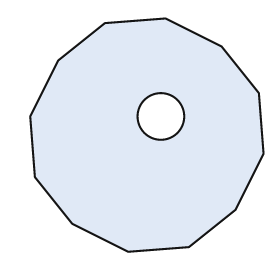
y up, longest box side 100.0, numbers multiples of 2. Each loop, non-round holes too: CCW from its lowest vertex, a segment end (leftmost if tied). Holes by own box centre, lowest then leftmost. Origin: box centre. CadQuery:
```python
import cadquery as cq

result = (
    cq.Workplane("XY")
    .moveTo(-8.0, -50.0)
    .lineTo(18.0, -48.0)
    .lineTo(38.0, -32.0)
    .lineTo(50.0, -8.0)
    .lineTo(48.0, 18.0)
    .lineTo(32.0, 38.0)
    .lineTo(8.0, 50.0)
    .lineTo(-18.0, 48.0)
    .lineTo(-38.0, 32.0)
    .lineTo(-50.0, 8.0)
    .lineTo(-48.0, -18.0)
    .lineTo(-32.0, -38.0)
    .close()
    .moveTo(6.0, 8.0)
    .circle(10.0)
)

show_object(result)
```